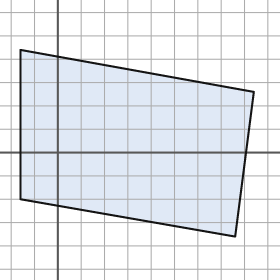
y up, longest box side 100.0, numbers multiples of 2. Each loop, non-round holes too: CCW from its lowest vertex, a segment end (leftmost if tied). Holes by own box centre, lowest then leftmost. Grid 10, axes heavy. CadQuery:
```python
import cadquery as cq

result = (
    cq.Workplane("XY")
    .moveTo(76.0, -36.0)
    .lineTo(84.0, 26.0)
    .lineTo(-16.0, 44.0)
    .lineTo(-16.0, -20.0)
    .close()
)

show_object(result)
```